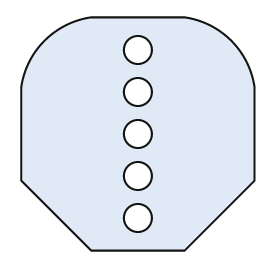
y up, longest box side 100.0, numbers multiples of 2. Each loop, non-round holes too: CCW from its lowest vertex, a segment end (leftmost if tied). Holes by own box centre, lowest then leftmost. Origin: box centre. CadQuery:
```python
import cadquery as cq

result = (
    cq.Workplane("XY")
    .moveTo(-20.0, -50.0)
    .lineTo(20.0, -50.0)
    .lineTo(50.0, -20.0)
    .lineTo(50.0, 20.0)
    .threePointArc((40.0, 40.0), (20.0, 50.0))
    .lineTo(-20.0, 50.0)
    .threePointArc((-40.0, 40.0), (-50.0, 20.0))
    .lineTo(-50.0, -20.0)
    .close()
    .moveTo(0.0, -36.0)
    .circle(6.0)
    .moveTo(0.0, -18.0)
    .circle(6.0)
    .moveTo(0.0, 0.0)
    .circle(6.0)
    .moveTo(0.0, 18.0)
    .circle(6.0)
    .moveTo(0.0, 36.0)
    .circle(6.0)
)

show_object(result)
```